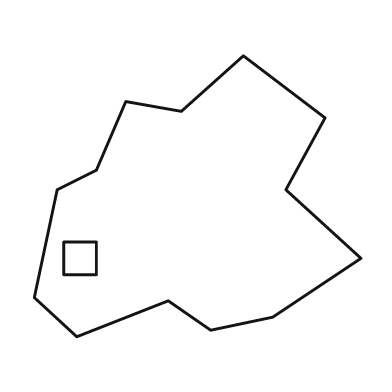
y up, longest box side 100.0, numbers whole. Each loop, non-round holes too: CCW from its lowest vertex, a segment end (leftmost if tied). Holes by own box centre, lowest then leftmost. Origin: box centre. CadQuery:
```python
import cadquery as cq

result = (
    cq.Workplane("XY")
    .moveTo(-37.0, -43.0)
    .lineTo(-9.0, -32.0)
    .lineTo(4.0, -41.0)
    .lineTo(23.0, -37.0)
    .lineTo(50.0, -19.0)
    .lineTo(27.0, 2.0)
    .lineTo(39.0, 24.0)
    .lineTo(14.0, 43.0)
    .lineTo(-5.0, 26.0)
    .lineTo(-22.0, 29.0)
    .lineTo(-31.0, 8.0)
    .lineTo(-43.0, 2.0)
    .lineTo(-50.0, -31.0)
    .close()
    .moveTo(-41.0, -24.0)
    .lineTo(-31.0, -24.0)
    .lineTo(-31.0, -14.0)
    .lineTo(-41.0, -14.0)
    .close()
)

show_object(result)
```